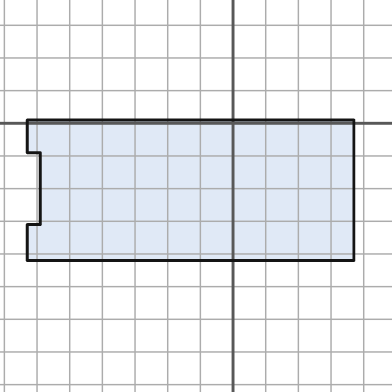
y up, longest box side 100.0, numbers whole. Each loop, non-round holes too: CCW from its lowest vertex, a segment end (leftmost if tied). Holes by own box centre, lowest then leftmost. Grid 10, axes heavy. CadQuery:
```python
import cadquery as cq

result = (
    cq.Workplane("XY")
    .moveTo(-63.0, -42.0)
    .lineTo(37.0, -42.0)
    .lineTo(37.0, 1.0)
    .lineTo(-63.0, 1.0)
    .lineTo(-63.0, -9.0)
    .lineTo(-59.0, -9.0)
    .lineTo(-59.0, -31.0)
    .lineTo(-63.0, -31.0)
    .close()
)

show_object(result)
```